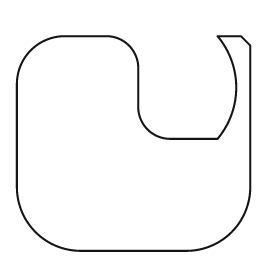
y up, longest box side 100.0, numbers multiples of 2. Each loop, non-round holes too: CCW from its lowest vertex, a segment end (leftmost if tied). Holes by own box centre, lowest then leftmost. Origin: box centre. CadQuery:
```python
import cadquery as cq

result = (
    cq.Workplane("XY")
    .moveTo(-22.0, -46.0)
    .lineTo(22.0, -46.0)
    .threePointArc((42.0, -38.0), (50.0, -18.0))
    .lineTo(50.0, 42.0)
    .lineTo(46.0, 46.0)
    .lineTo(36.0, 46.0)
    .threePointArc((44.0, 24.0), (36.0, 2.0))
    .lineTo(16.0, 2.0)
    .threePointArc((6.0, 6.0), (2.0, 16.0))
    .lineTo(2.0, 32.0)
    .threePointArc((-2.0, 42.0), (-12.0, 46.0))
    .lineTo(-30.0, 46.0)
    .threePointArc((-44.0, 40.0), (-50.0, 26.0))
    .lineTo(-50.0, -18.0)
    .threePointArc((-42.0, -38.0), (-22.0, -46.0))
    .close()
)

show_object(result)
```